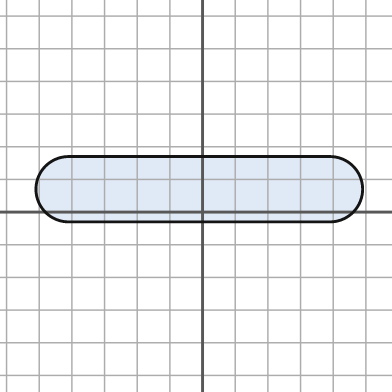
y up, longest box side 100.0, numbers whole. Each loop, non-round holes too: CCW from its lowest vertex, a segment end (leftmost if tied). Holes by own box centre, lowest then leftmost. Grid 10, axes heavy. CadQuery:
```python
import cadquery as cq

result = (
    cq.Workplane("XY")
    .moveTo(-41.0, -3.0)
    .lineTo(39.0, -3.0)
    .threePointArc((49.0, 7.0), (39.0, 17.0))
    .lineTo(-41.0, 17.0)
    .threePointArc((-51.0, 7.0), (-41.0, -3.0))
    .close()
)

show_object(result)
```